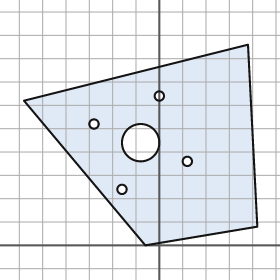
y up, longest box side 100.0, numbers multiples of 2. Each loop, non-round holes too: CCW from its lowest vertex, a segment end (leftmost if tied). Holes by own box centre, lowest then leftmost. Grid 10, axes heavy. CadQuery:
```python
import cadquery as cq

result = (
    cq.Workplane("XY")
    .moveTo(-6.0, 0.0)
    .lineTo(42.0, 8.0)
    .lineTo(38.0, 86.0)
    .lineTo(-58.0, 62.0)
    .close()
    .moveTo(-16.0, 24.0)
    .circle(2.0)
    .moveTo(12.0, 36.0)
    .circle(2.0)
    .moveTo(-8.0, 44.0)
    .circle(8.0)
    .moveTo(-28.0, 52.0)
    .circle(2.0)
    .moveTo(0.0, 64.0)
    .circle(2.0)
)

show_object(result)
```